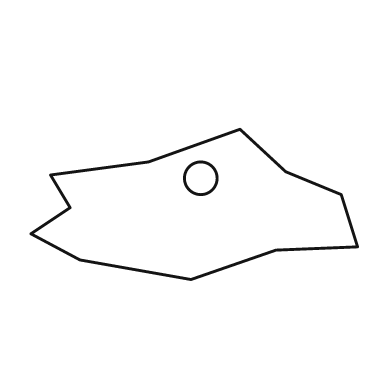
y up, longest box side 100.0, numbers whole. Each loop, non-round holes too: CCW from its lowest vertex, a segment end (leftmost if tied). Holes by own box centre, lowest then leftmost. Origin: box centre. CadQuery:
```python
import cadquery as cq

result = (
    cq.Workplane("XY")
    .moveTo(-1.0, -23.0)
    .lineTo(25.0, -14.0)
    .lineTo(50.0, -13.0)
    .lineTo(45.0, 3.0)
    .lineTo(28.0, 10.0)
    .lineTo(14.0, 23.0)
    .lineTo(-14.0, 13.0)
    .lineTo(-44.0, 9.0)
    .lineTo(-38.0, -1.0)
    .lineTo(-50.0, -9.0)
    .lineTo(-35.0, -17.0)
    .close()
    .moveTo(2.0, 8.0)
    .circle(5.0)
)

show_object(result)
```